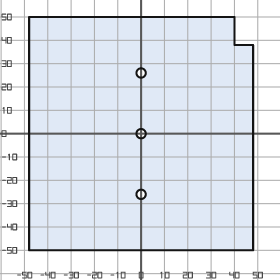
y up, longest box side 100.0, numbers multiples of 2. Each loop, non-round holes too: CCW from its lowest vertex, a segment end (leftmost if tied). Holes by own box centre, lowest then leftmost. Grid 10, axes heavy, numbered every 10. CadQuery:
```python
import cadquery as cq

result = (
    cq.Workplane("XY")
    .moveTo(-48.0, -50.0)
    .lineTo(48.0, -50.0)
    .lineTo(48.0, 38.0)
    .lineTo(40.0, 38.0)
    .lineTo(40.0, 50.0)
    .lineTo(-48.0, 50.0)
    .close()
    .moveTo(0.0, -26.0)
    .circle(2.0)
    .moveTo(0.0, 0.0)
    .circle(2.0)
    .moveTo(0.0, 26.0)
    .circle(2.0)
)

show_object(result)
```